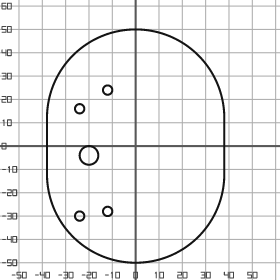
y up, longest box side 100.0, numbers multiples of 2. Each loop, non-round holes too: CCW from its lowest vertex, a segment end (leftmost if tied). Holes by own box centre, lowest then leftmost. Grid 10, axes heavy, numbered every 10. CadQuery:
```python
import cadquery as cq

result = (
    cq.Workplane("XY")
    .moveTo(-38.0, -12.0)
    .threePointArc((0.0, -50.0), (38.0, -12.0))
    .lineTo(38.0, 12.0)
    .threePointArc((0.0, 50.0), (-38.0, 12.0))
    .close()
    .moveTo(-24.0, -30.0)
    .circle(2.0)
    .moveTo(-12.0, -28.0)
    .circle(2.0)
    .moveTo(-20.0, -4.0)
    .circle(4.0)
    .moveTo(-24.0, 16.0)
    .circle(2.0)
    .moveTo(-12.0, 24.0)
    .circle(2.0)
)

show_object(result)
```